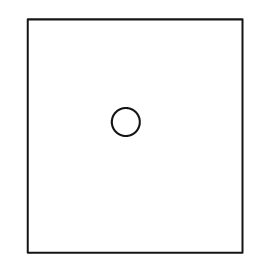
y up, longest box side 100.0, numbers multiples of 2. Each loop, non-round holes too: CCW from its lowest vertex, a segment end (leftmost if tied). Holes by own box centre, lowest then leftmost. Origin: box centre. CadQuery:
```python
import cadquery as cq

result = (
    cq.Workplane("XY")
    .moveTo(-46.0, -50.0)
    .lineTo(46.0, -50.0)
    .lineTo(46.0, 50.0)
    .lineTo(-46.0, 50.0)
    .close()
    .moveTo(-4.0, 6.0)
    .circle(6.0)
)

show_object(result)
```